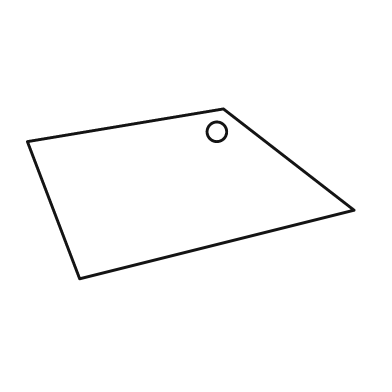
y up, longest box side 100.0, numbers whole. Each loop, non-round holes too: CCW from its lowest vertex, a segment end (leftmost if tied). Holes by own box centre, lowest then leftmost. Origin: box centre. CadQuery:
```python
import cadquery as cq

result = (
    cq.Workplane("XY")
    .moveTo(-34.0, -26.0)
    .lineTo(50.0, -5.0)
    .lineTo(10.0, 26.0)
    .lineTo(-50.0, 16.0)
    .close()
    .moveTo(8.0, 19.0)
    .circle(3.0)
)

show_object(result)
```